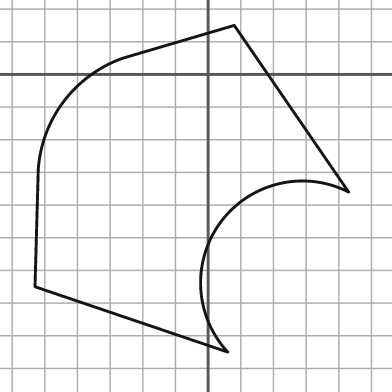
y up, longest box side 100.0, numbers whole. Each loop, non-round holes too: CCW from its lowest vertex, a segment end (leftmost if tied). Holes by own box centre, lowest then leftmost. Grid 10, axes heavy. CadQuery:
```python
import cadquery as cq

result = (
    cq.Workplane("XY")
    .moveTo(6.0, -85.0)
    .threePointArc((4.0, -45.0), (43.0, -36.0))
    .lineTo(8.0, 15.0)
    .lineTo(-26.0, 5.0)
    .threePointArc((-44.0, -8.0), (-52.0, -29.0))
    .lineTo(-53.0, -65.0)
    .close()
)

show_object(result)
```